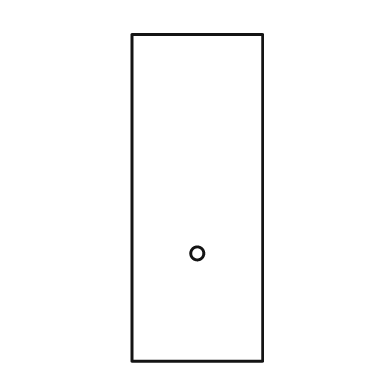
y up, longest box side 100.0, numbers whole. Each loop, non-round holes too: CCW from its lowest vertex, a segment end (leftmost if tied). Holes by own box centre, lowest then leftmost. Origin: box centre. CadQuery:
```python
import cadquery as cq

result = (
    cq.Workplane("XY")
    .moveTo(-20.0, -50.0)
    .lineTo(20.0, -50.0)
    .lineTo(20.0, 50.0)
    .lineTo(-20.0, 50.0)
    .close()
    .moveTo(0.0, -17.0)
    .circle(2.0)
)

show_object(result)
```